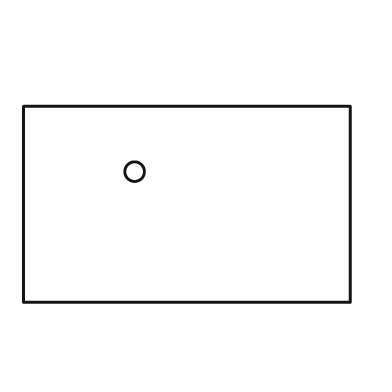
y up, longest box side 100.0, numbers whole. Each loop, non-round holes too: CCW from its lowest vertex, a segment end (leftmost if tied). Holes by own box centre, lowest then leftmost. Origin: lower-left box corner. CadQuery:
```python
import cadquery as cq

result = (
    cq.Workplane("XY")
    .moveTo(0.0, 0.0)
    .lineTo(100.0, 0.0)
    .lineTo(100.0, 60.0)
    .lineTo(0.0, 60.0)
    .close()
    .moveTo(34.0, 40.0)
    .circle(3.0)
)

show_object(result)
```